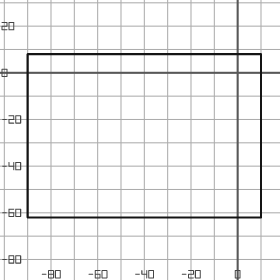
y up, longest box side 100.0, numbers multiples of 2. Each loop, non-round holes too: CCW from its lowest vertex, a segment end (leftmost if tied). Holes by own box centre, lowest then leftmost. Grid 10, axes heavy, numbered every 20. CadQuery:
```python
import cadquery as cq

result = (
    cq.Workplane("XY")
    .moveTo(-90.0, -62.0)
    .lineTo(10.0, -62.0)
    .lineTo(10.0, 8.0)
    .lineTo(-90.0, 8.0)
    .close()
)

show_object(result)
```